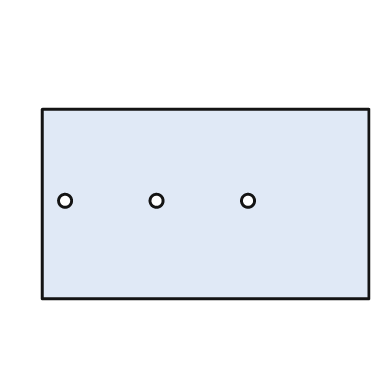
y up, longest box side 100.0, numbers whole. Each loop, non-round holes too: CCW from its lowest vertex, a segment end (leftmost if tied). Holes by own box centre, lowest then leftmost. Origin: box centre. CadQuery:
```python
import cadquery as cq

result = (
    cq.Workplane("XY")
    .moveTo(-50.0, -29.0)
    .lineTo(50.0, -29.0)
    .lineTo(50.0, 29.0)
    .lineTo(-50.0, 29.0)
    .close()
    .moveTo(-43.0, 1.0)
    .circle(2.0)
    .moveTo(-15.0, 1.0)
    .circle(2.0)
    .moveTo(13.0, 1.0)
    .circle(2.0)
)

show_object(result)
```